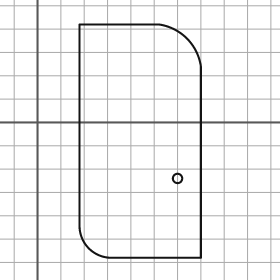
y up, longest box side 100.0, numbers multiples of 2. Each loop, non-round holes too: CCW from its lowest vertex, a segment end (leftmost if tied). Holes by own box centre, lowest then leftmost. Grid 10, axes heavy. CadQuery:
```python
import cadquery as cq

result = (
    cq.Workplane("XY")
    .moveTo(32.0, -58.0)
    .lineTo(70.0, -58.0)
    .lineTo(70.0, 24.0)
    .threePointArc((64.0, 36.0), (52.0, 42.0))
    .lineTo(18.0, 42.0)
    .lineTo(18.0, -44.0)
    .threePointArc((22.0, -54.0), (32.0, -58.0))
    .close()
    .moveTo(60.0, -24.0)
    .circle(2.0)
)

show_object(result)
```